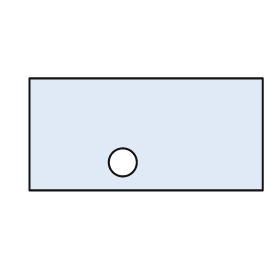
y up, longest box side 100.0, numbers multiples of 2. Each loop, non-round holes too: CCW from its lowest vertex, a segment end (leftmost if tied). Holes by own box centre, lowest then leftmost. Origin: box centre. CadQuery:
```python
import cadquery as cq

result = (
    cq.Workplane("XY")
    .moveTo(-50.0, -24.0)
    .lineTo(50.0, -24.0)
    .lineTo(50.0, 24.0)
    .lineTo(-50.0, 24.0)
    .close()
    .moveTo(-10.0, -12.0)
    .circle(6.0)
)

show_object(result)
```